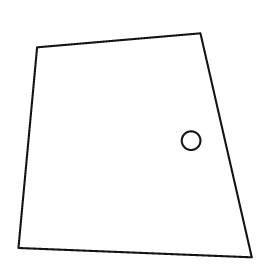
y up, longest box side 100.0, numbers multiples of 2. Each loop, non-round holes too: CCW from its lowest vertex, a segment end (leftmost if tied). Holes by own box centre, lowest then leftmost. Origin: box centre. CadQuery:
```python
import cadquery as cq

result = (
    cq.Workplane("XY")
    .moveTo(50.0, -48.0)
    .lineTo(28.0, 48.0)
    .lineTo(-42.0, 42.0)
    .lineTo(-50.0, -44.0)
    .close()
    .moveTo(24.0, 2.0)
    .circle(4.0)
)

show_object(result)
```